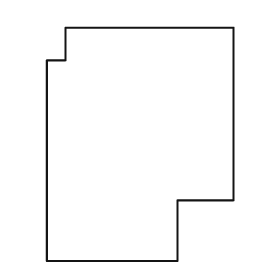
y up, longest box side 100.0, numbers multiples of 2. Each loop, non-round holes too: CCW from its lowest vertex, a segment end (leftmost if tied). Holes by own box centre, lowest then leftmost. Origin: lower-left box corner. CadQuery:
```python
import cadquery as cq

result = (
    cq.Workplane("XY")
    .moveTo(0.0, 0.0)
    .lineTo(56.0, 0.0)
    .lineTo(56.0, 26.0)
    .lineTo(80.0, 26.0)
    .lineTo(80.0, 100.0)
    .lineTo(8.0, 100.0)
    .lineTo(8.0, 86.0)
    .lineTo(0.0, 86.0)
    .close()
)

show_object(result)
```